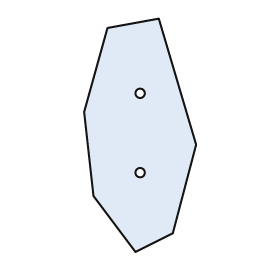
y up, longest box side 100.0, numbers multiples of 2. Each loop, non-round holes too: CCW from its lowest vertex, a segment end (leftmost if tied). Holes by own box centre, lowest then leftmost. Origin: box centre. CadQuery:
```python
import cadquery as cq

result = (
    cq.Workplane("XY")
    .moveTo(-2.0, -50.0)
    .lineTo(14.0, -42.0)
    .lineTo(24.0, -4.0)
    .lineTo(8.0, 50.0)
    .lineTo(-14.0, 46.0)
    .lineTo(-24.0, 10.0)
    .lineTo(-20.0, -26.0)
    .close()
    .moveTo(0.0, -16.0)
    .circle(2.0)
    .moveTo(0.0, 18.0)
    .circle(2.0)
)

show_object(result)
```